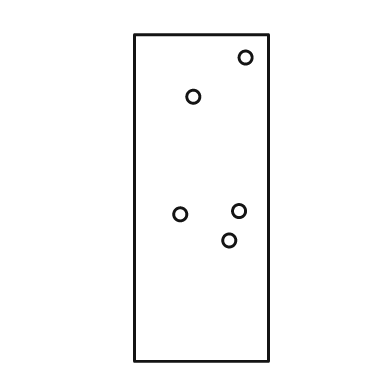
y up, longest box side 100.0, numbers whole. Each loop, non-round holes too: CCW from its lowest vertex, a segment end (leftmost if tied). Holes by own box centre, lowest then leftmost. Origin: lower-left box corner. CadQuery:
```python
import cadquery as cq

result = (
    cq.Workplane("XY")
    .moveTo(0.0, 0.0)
    .lineTo(41.0, 0.0)
    .lineTo(41.0, 100.0)
    .lineTo(0.0, 100.0)
    .close()
    .moveTo(29.0, 37.0)
    .circle(2.0)
    .moveTo(14.0, 45.0)
    .circle(2.0)
    .moveTo(32.0, 46.0)
    .circle(2.0)
    .moveTo(18.0, 81.0)
    .circle(2.0)
    .moveTo(34.0, 93.0)
    .circle(2.0)
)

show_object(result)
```